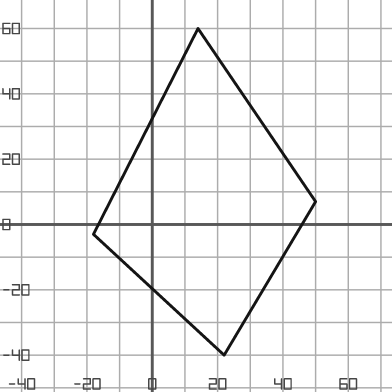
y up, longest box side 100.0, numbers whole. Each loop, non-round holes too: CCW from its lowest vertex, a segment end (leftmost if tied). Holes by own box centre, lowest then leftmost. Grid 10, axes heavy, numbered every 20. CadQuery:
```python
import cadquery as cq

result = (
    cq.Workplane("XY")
    .moveTo(22.0, -40.0)
    .lineTo(50.0, 7.0)
    .lineTo(14.0, 60.0)
    .lineTo(-18.0, -3.0)
    .close()
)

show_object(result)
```